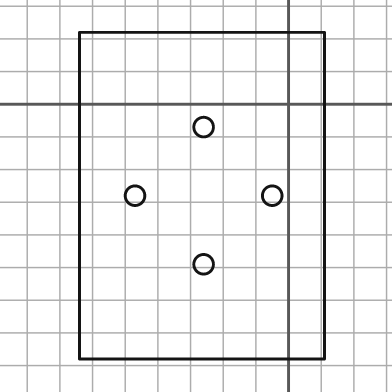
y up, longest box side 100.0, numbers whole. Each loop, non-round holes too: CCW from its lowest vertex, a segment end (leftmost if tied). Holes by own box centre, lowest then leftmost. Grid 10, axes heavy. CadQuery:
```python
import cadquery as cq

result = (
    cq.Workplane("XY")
    .moveTo(-64.0, -78.0)
    .lineTo(11.0, -78.0)
    .lineTo(11.0, 22.0)
    .lineTo(-64.0, 22.0)
    .close()
    .moveTo(-26.0, -49.0)
    .circle(3.0)
    .moveTo(-47.0, -28.0)
    .circle(3.0)
    .moveTo(-5.0, -28.0)
    .circle(3.0)
    .moveTo(-26.0, -7.0)
    .circle(3.0)
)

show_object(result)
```